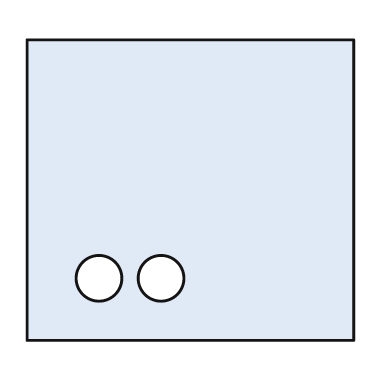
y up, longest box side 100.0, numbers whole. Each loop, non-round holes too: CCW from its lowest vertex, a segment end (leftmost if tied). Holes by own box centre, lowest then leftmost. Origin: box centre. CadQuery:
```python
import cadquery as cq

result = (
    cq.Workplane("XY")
    .moveTo(-50.0, -46.0)
    .lineTo(50.0, -46.0)
    .lineTo(50.0, 46.0)
    .lineTo(-50.0, 46.0)
    .close()
    .moveTo(-28.0, -27.0)
    .circle(7.0)
    .moveTo(-9.0, -27.0)
    .circle(7.0)
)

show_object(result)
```